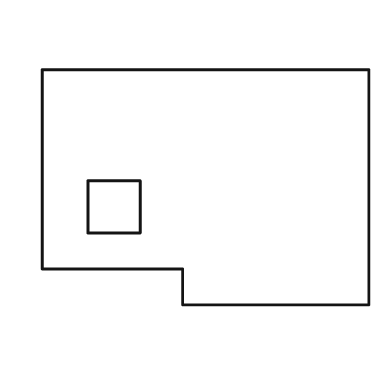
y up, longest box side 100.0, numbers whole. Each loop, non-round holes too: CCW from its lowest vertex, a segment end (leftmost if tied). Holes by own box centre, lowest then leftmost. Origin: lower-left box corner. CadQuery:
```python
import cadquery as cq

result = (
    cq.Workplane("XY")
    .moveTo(43.0, 0.0)
    .lineTo(100.0, 0.0)
    .lineTo(100.0, 72.0)
    .lineTo(0.0, 72.0)
    .lineTo(0.0, 11.0)
    .lineTo(43.0, 11.0)
    .close()
    .moveTo(14.0, 22.0)
    .lineTo(30.0, 22.0)
    .lineTo(30.0, 38.0)
    .lineTo(14.0, 38.0)
    .close()
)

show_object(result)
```